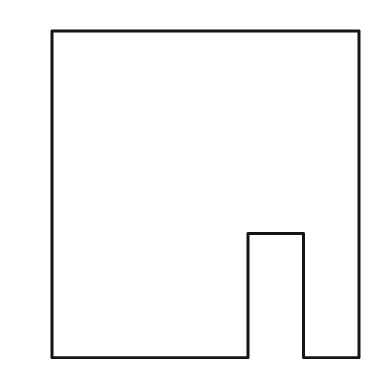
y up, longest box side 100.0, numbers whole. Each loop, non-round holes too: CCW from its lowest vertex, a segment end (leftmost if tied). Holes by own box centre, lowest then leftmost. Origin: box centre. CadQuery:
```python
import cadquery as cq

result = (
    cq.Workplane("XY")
    .moveTo(-47.0, -50.0)
    .lineTo(13.0, -50.0)
    .lineTo(13.0, -12.0)
    .lineTo(30.0, -12.0)
    .lineTo(30.0, -50.0)
    .lineTo(47.0, -50.0)
    .lineTo(47.0, 50.0)
    .lineTo(-47.0, 50.0)
    .close()
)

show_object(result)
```